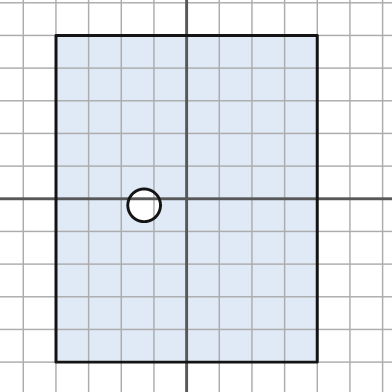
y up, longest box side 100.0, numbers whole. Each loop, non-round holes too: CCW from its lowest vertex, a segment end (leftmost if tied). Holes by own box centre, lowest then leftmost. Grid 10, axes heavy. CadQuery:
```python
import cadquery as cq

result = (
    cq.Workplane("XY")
    .moveTo(-40.0, -50.0)
    .lineTo(40.0, -50.0)
    .lineTo(40.0, 50.0)
    .lineTo(-40.0, 50.0)
    .close()
    .moveTo(-13.0, -2.0)
    .circle(5.0)
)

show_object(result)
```